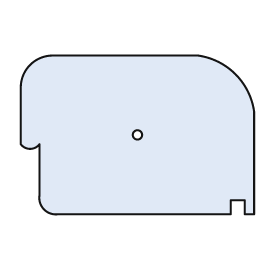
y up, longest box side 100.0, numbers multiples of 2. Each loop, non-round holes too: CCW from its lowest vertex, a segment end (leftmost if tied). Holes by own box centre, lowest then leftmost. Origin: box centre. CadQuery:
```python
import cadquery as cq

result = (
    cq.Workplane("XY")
    .moveTo(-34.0, -34.0)
    .lineTo(40.0, -34.0)
    .lineTo(40.0, -28.0)
    .lineTo(46.0, -28.0)
    .lineTo(46.0, -34.0)
    .lineTo(50.0, -34.0)
    .lineTo(50.0, 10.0)
    .threePointArc((42.0, 26.0), (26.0, 34.0))
    .lineTo(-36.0, 34.0)
    .threePointArc((-46.0, 30.0), (-50.0, 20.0))
    .lineTo(-50.0, -4.0)
    .threePointArc((-46.0, -6.0), (-42.0, -4.0))
    .lineTo(-42.0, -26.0)
    .threePointArc((-40.0, -32.0), (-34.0, -34.0))
    .close()
    .moveTo(0.0, 0.0)
    .circle(2.0)
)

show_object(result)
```